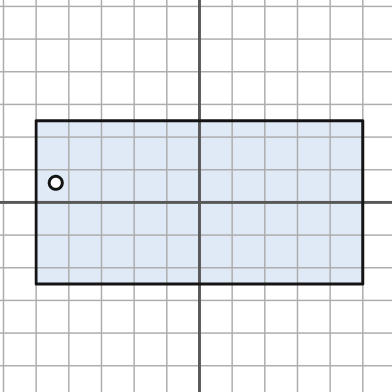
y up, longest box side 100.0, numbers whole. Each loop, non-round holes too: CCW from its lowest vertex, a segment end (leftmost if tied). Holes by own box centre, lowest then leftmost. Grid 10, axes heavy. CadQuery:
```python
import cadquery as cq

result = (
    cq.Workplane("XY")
    .moveTo(-50.0, -25.0)
    .lineTo(50.0, -25.0)
    .lineTo(50.0, 25.0)
    .lineTo(-50.0, 25.0)
    .close()
    .moveTo(-44.0, 6.0)
    .circle(2.0)
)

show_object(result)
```